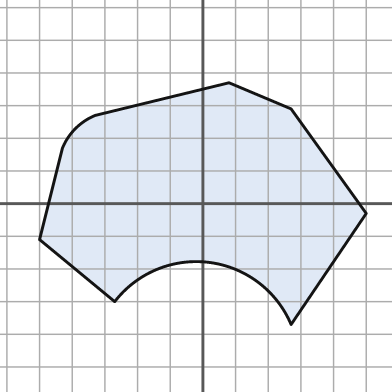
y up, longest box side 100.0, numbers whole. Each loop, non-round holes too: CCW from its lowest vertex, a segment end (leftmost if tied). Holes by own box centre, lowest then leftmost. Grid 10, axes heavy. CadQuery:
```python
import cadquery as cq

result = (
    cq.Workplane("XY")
    .moveTo(27.0, -37.0)
    .lineTo(50.0, -3.0)
    .lineTo(27.0, 29.0)
    .lineTo(8.0, 37.0)
    .lineTo(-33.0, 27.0)
    .threePointArc((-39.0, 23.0), (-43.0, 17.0))
    .lineTo(-50.0, -11.0)
    .lineTo(-27.0, -30.0)
    .threePointArc((2.0, -18.0), (27.0, -37.0))
    .close()
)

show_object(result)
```